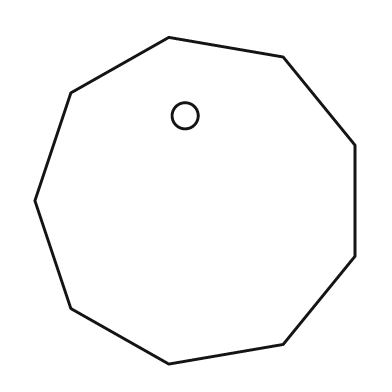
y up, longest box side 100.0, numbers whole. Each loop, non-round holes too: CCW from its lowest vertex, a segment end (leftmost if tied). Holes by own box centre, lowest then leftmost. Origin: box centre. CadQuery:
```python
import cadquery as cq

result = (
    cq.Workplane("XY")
    .moveTo(-8.0, -50.0)
    .lineTo(27.0, -44.0)
    .lineTo(49.0, -17.0)
    .lineTo(49.0, 17.0)
    .lineTo(27.0, 44.0)
    .lineTo(-8.0, 50.0)
    .lineTo(-38.0, 33.0)
    .lineTo(-49.0, 0.0)
    .lineTo(-38.0, -33.0)
    .close()
    .moveTo(-3.0, 26.0)
    .circle(4.0)
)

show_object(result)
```